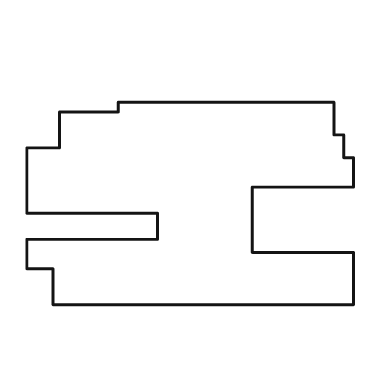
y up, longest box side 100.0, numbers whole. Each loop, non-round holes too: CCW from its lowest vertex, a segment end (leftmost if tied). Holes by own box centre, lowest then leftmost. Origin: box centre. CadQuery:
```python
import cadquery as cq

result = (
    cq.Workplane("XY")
    .moveTo(-42.0, -31.0)
    .lineTo(50.0, -31.0)
    .lineTo(50.0, -15.0)
    .lineTo(19.0, -15.0)
    .lineTo(19.0, 5.0)
    .lineTo(50.0, 5.0)
    .lineTo(50.0, 14.0)
    .lineTo(47.0, 14.0)
    .lineTo(47.0, 21.0)
    .lineTo(44.0, 21.0)
    .lineTo(44.0, 31.0)
    .lineTo(-22.0, 31.0)
    .lineTo(-22.0, 28.0)
    .lineTo(-40.0, 28.0)
    .lineTo(-40.0, 17.0)
    .lineTo(-50.0, 17.0)
    .lineTo(-50.0, -3.0)
    .lineTo(-10.0, -3.0)
    .lineTo(-10.0, -11.0)
    .lineTo(-50.0, -11.0)
    .lineTo(-50.0, -20.0)
    .lineTo(-42.0, -20.0)
    .close()
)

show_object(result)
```